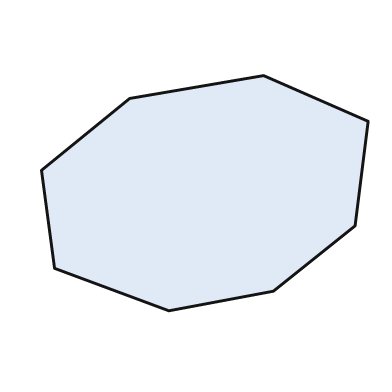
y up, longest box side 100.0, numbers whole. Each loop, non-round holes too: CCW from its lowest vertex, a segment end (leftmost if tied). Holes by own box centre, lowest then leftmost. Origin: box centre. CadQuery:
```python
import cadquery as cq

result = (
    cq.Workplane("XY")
    .moveTo(-11.0, -36.0)
    .lineTo(21.0, -30.0)
    .lineTo(46.0, -10.0)
    .lineTo(50.0, 22.0)
    .lineTo(18.0, 36.0)
    .lineTo(-23.0, 29.0)
    .lineTo(-50.0, 7.0)
    .lineTo(-46.0, -23.0)
    .close()
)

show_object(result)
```